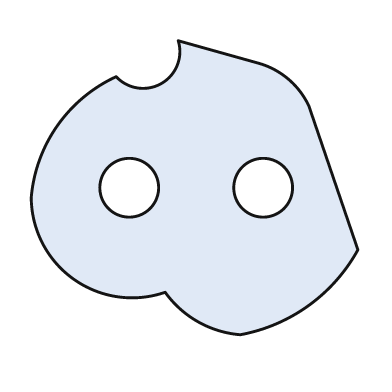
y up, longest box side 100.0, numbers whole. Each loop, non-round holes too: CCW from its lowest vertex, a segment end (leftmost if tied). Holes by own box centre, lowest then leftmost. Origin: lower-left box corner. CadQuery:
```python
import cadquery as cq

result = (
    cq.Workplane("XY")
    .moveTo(64.0, 0.0)
    .threePointArc((85.0, 9.0), (100.0, 26.0))
    .lineTo(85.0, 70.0)
    .threePointArc((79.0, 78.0), (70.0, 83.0))
    .lineTo(45.0, 90.0)
    .threePointArc((40.0, 77.0), (26.0, 79.0))
    .threePointArc((8.0, 64.0), (0.0, 42.0))
    .threePointArc((13.0, 17.0), (41.0, 13.0))
    .threePointArc((51.0, 4.0), (64.0, 0.0))
    .close()
    .moveTo(30.0, 45.0)
    .circle(9.0)
    .moveTo(71.0, 45.0)
    .circle(9.0)
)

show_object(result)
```